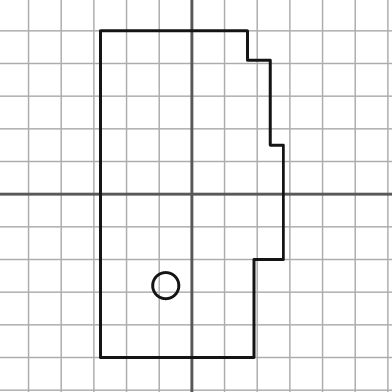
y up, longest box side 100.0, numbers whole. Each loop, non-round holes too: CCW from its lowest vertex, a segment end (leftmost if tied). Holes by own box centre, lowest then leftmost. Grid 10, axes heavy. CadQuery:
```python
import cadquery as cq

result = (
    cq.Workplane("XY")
    .moveTo(-28.0, -50.0)
    .lineTo(19.0, -50.0)
    .lineTo(19.0, -20.0)
    .lineTo(28.0, -20.0)
    .lineTo(28.0, 15.0)
    .lineTo(24.0, 15.0)
    .lineTo(24.0, 41.0)
    .lineTo(17.0, 41.0)
    .lineTo(17.0, 50.0)
    .lineTo(-28.0, 50.0)
    .close()
    .moveTo(-8.0, -28.0)
    .circle(4.0)
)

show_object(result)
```